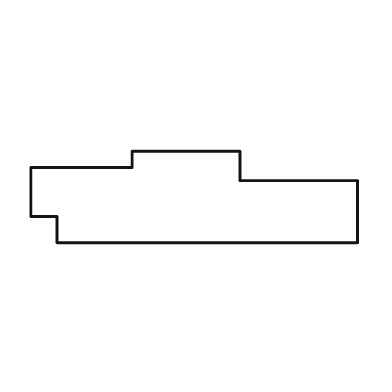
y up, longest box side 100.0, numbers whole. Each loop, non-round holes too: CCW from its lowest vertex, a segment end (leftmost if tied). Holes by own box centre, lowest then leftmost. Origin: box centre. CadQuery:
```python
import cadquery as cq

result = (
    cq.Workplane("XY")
    .moveTo(-42.0, -14.0)
    .lineTo(50.0, -14.0)
    .lineTo(50.0, 5.0)
    .lineTo(14.0, 5.0)
    .lineTo(14.0, 14.0)
    .lineTo(-19.0, 14.0)
    .lineTo(-19.0, 9.0)
    .lineTo(-50.0, 9.0)
    .lineTo(-50.0, -6.0)
    .lineTo(-42.0, -6.0)
    .close()
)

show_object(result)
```